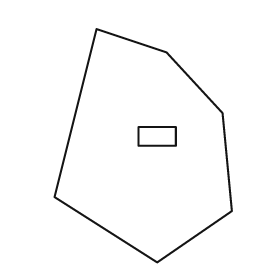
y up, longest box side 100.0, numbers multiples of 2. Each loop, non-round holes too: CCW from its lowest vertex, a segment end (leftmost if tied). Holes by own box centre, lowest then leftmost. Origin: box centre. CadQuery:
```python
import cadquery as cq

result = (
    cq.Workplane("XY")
    .moveTo(6.0, -50.0)
    .lineTo(38.0, -28.0)
    .lineTo(34.0, 14.0)
    .lineTo(10.0, 40.0)
    .lineTo(-20.0, 50.0)
    .lineTo(-38.0, -22.0)
    .close()
    .moveTo(-2.0, 0.0)
    .lineTo(14.0, 0.0)
    .lineTo(14.0, 8.0)
    .lineTo(-2.0, 8.0)
    .close()
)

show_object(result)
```